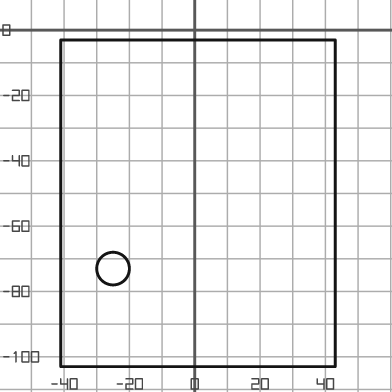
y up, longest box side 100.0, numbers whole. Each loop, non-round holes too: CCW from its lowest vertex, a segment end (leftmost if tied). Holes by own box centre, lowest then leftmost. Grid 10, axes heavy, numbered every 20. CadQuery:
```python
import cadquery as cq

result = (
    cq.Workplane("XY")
    .moveTo(-41.0, -103.0)
    .lineTo(43.0, -103.0)
    .lineTo(43.0, -3.0)
    .lineTo(-41.0, -3.0)
    .close()
    .moveTo(-25.0, -73.0)
    .circle(5.0)
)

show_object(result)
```